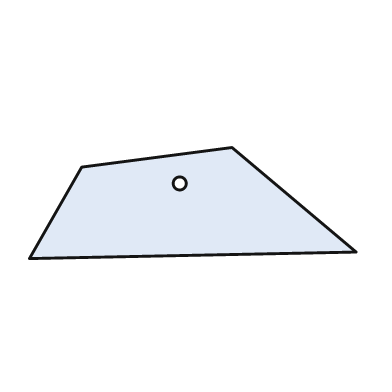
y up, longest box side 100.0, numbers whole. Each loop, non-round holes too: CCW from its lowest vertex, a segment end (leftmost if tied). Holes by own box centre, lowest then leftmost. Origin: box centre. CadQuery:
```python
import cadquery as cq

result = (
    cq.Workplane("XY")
    .moveTo(-50.0, -17.0)
    .lineTo(50.0, -15.0)
    .lineTo(12.0, 17.0)
    .lineTo(-34.0, 11.0)
    .close()
    .moveTo(-4.0, 6.0)
    .circle(2.0)
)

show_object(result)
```